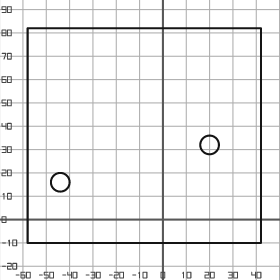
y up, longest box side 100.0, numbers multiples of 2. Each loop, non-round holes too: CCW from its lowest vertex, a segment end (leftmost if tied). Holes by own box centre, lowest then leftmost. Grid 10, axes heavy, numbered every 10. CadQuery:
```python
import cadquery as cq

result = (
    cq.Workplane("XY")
    .moveTo(-58.0, -10.0)
    .lineTo(42.0, -10.0)
    .lineTo(42.0, 82.0)
    .lineTo(-58.0, 82.0)
    .close()
    .moveTo(-44.0, 16.0)
    .circle(4.0)
    .moveTo(20.0, 32.0)
    .circle(4.0)
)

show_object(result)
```